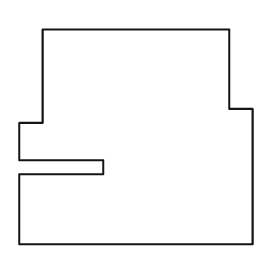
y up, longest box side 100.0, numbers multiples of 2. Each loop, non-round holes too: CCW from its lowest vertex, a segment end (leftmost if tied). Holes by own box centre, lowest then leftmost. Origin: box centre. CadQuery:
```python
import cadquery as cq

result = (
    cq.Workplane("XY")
    .moveTo(-50.0, -46.0)
    .lineTo(50.0, -46.0)
    .lineTo(50.0, 12.0)
    .lineTo(40.0, 12.0)
    .lineTo(40.0, 46.0)
    .lineTo(-40.0, 46.0)
    .lineTo(-40.0, 6.0)
    .lineTo(-50.0, 6.0)
    .lineTo(-50.0, -10.0)
    .lineTo(-14.0, -10.0)
    .lineTo(-14.0, -16.0)
    .lineTo(-50.0, -16.0)
    .close()
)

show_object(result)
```